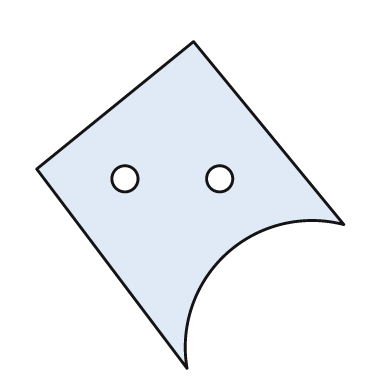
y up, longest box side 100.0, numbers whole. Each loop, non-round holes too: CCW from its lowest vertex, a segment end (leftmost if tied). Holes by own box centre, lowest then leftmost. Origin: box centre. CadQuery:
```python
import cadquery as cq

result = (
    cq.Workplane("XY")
    .moveTo(-1.0, -50.0)
    .threePointArc((11.0, -15.0), (47.0, -6.0))
    .lineTo(1.0, 50.0)
    .lineTo(-47.0, 11.0)
    .close()
    .moveTo(-20.0, 8.0)
    .circle(4.0)
    .moveTo(9.0, 8.0)
    .circle(4.0)
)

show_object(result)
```